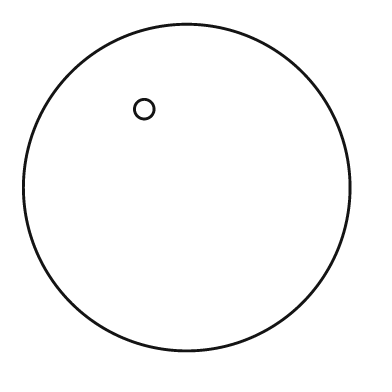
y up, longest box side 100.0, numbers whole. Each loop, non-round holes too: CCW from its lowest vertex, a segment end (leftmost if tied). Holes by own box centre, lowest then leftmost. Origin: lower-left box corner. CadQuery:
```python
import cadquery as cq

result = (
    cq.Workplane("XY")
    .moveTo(50.0, 50.0)
    .circle(50.0)
    .moveTo(37.0, 74.0)
    .circle(3.0)
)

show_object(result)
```